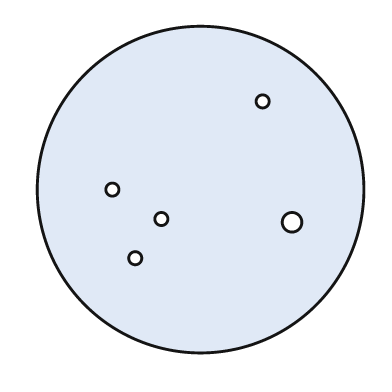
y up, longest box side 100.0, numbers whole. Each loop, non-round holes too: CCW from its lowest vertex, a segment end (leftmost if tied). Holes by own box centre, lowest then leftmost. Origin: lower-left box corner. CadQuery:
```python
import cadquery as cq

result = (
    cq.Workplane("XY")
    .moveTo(50.0, 50.0)
    .circle(50.0)
    .moveTo(30.0, 29.0)
    .circle(2.0)
    .moveTo(78.0, 40.0)
    .circle(3.0)
    .moveTo(38.0, 41.0)
    .circle(2.0)
    .moveTo(23.0, 50.0)
    .circle(2.0)
    .moveTo(69.0, 77.0)
    .circle(2.0)
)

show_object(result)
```